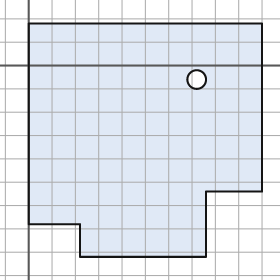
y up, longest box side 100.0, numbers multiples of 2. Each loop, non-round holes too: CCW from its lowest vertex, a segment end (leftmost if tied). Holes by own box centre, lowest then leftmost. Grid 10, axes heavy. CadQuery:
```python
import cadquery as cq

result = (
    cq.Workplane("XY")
    .moveTo(22.0, -82.0)
    .lineTo(76.0, -82.0)
    .lineTo(76.0, -54.0)
    .lineTo(100.0, -54.0)
    .lineTo(100.0, 18.0)
    .lineTo(0.0, 18.0)
    .lineTo(0.0, -68.0)
    .lineTo(22.0, -68.0)
    .close()
    .moveTo(72.0, -6.0)
    .circle(4.0)
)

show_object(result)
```